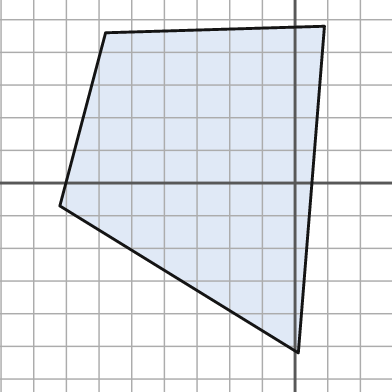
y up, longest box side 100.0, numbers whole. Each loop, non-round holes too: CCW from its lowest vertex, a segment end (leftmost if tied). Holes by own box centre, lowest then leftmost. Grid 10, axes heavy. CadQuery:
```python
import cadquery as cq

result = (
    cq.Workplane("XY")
    .moveTo(1.0, -52.0)
    .lineTo(9.0, 48.0)
    .lineTo(-58.0, 46.0)
    .lineTo(-72.0, -7.0)
    .close()
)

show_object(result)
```